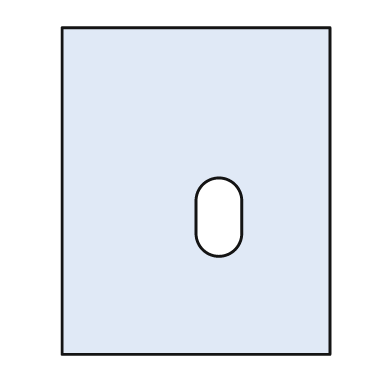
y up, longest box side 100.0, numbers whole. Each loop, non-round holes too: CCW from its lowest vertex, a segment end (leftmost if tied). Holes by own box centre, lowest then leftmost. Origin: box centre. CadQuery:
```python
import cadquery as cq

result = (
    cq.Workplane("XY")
    .moveTo(-41.0, -50.0)
    .lineTo(41.0, -50.0)
    .lineTo(41.0, 50.0)
    .lineTo(-41.0, 50.0)
    .close()
    .moveTo(0.0, -13.0)
    .threePointArc((7.0, -20.0), (14.0, -13.0))
    .lineTo(14.0, -3.0)
    .threePointArc((7.0, 4.0), (0.0, -3.0))
    .close()
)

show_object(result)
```